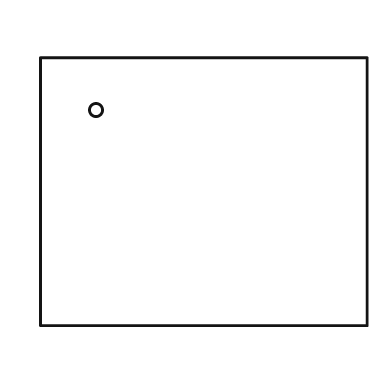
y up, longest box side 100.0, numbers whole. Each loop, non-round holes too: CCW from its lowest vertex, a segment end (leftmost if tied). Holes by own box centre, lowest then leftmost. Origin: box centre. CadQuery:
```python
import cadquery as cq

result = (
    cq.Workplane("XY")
    .moveTo(-50.0, -41.0)
    .lineTo(50.0, -41.0)
    .lineTo(50.0, 41.0)
    .lineTo(-50.0, 41.0)
    .close()
    .moveTo(-33.0, 25.0)
    .circle(2.0)
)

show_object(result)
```